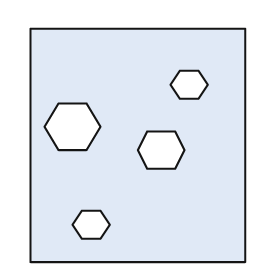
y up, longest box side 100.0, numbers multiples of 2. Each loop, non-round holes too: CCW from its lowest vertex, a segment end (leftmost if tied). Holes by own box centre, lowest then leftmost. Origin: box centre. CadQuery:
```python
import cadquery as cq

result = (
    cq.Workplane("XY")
    .moveTo(-46.0, -50.0)
    .lineTo(46.0, -50.0)
    .lineTo(46.0, 50.0)
    .lineTo(-46.0, 50.0)
    .close()
    .moveTo(-24.0, -40.0)
    .lineTo(-16.0, -40.0)
    .lineTo(-12.0, -34.0)
    .lineTo(-16.0, -28.0)
    .lineTo(-24.0, -28.0)
    .lineTo(-28.0, -34.0)
    .close()
    .moveTo(4.0, -10.0)
    .lineTo(16.0, -10.0)
    .lineTo(20.0, -2.0)
    .lineTo(16.0, 6.0)
    .lineTo(4.0, 6.0)
    .lineTo(0.0, -2.0)
    .close()
    .moveTo(-34.0, -2.0)
    .lineTo(-22.0, -2.0)
    .lineTo(-16.0, 8.0)
    .lineTo(-22.0, 18.0)
    .lineTo(-34.0, 18.0)
    .lineTo(-40.0, 8.0)
    .close()
    .moveTo(18.0, 20.0)
    .lineTo(26.0, 20.0)
    .lineTo(30.0, 26.0)
    .lineTo(26.0, 32.0)
    .lineTo(18.0, 32.0)
    .lineTo(14.0, 26.0)
    .close()
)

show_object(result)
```